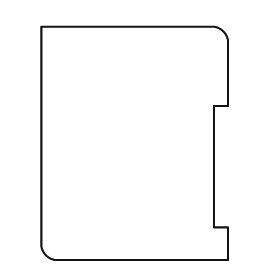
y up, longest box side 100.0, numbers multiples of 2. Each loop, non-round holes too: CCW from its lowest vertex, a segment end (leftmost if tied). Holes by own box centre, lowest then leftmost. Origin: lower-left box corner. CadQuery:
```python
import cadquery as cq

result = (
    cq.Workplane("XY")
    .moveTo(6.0, 0.0)
    .lineTo(80.0, 0.0)
    .lineTo(80.0, 14.0)
    .lineTo(74.0, 14.0)
    .lineTo(74.0, 66.0)
    .lineTo(80.0, 66.0)
    .lineTo(80.0, 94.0)
    .threePointArc((78.0, 98.0), (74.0, 100.0))
    .lineTo(0.0, 100.0)
    .lineTo(0.0, 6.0)
    .threePointArc((2.0, 2.0), (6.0, 0.0))
    .close()
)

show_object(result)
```